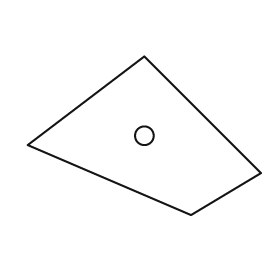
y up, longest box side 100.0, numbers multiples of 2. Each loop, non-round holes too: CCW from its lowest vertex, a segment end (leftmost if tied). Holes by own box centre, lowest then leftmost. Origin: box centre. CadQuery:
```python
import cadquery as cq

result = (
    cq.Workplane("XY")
    .moveTo(20.0, -34.0)
    .lineTo(50.0, -16.0)
    .lineTo(0.0, 34.0)
    .lineTo(-50.0, -4.0)
    .close()
    .moveTo(0.0, 0.0)
    .circle(4.0)
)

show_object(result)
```